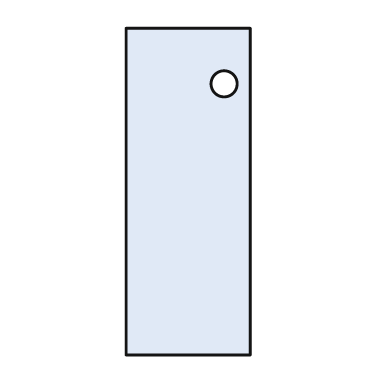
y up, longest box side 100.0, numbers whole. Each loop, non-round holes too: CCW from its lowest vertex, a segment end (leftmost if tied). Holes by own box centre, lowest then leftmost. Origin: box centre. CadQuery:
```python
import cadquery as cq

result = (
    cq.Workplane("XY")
    .moveTo(-19.0, -50.0)
    .lineTo(19.0, -50.0)
    .lineTo(19.0, 50.0)
    .lineTo(-19.0, 50.0)
    .close()
    .moveTo(11.0, 33.0)
    .circle(4.0)
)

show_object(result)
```